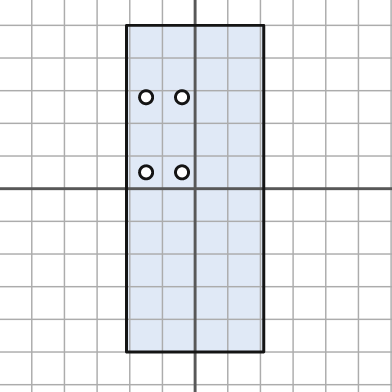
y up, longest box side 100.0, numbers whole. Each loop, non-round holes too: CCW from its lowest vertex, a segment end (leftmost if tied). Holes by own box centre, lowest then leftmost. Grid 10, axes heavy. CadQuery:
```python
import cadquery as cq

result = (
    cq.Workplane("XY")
    .moveTo(-21.0, -50.0)
    .lineTo(21.0, -50.0)
    .lineTo(21.0, 50.0)
    .lineTo(-21.0, 50.0)
    .close()
    .moveTo(-15.0, 5.0)
    .circle(2.0)
    .moveTo(-4.0, 5.0)
    .circle(2.0)
    .moveTo(-15.0, 28.0)
    .circle(2.0)
    .moveTo(-4.0, 28.0)
    .circle(2.0)
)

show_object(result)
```